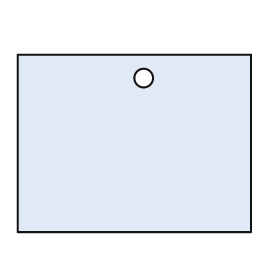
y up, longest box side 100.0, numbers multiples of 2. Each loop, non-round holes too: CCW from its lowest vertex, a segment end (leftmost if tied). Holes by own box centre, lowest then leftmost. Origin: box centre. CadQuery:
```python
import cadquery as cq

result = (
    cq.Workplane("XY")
    .moveTo(-50.0, -38.0)
    .lineTo(50.0, -38.0)
    .lineTo(50.0, 38.0)
    .lineTo(-50.0, 38.0)
    .close()
    .moveTo(4.0, 28.0)
    .circle(4.0)
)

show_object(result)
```